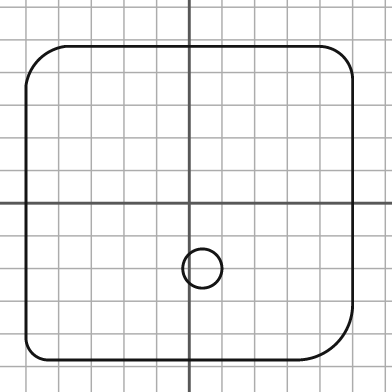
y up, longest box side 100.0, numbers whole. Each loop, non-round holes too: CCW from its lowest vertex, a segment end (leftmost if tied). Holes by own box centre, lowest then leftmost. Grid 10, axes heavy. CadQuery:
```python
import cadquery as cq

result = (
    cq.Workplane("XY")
    .moveTo(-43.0, -48.0)
    .lineTo(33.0, -48.0)
    .threePointArc((45.0, -43.0), (50.0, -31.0))
    .lineTo(50.0, 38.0)
    .threePointArc((47.0, 45.0), (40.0, 48.0))
    .lineTo(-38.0, 48.0)
    .threePointArc((-46.0, 44.0), (-50.0, 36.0))
    .lineTo(-50.0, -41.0)
    .threePointArc((-48.0, -46.0), (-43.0, -48.0))
    .close()
    .moveTo(4.0, -20.0)
    .circle(6.0)
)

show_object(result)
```